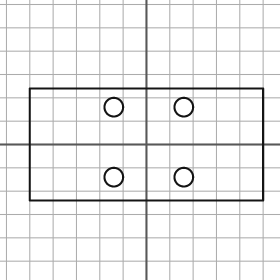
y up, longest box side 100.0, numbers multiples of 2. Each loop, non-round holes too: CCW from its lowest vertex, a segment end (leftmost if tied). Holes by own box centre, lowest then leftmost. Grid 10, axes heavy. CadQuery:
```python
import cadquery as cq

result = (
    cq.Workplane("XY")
    .moveTo(-50.0, -24.0)
    .lineTo(50.0, -24.0)
    .lineTo(50.0, 24.0)
    .lineTo(-50.0, 24.0)
    .close()
    .moveTo(-14.0, -14.0)
    .circle(4.0)
    .moveTo(16.0, -14.0)
    .circle(4.0)
    .moveTo(-14.0, 16.0)
    .circle(4.0)
    .moveTo(16.0, 16.0)
    .circle(4.0)
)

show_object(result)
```